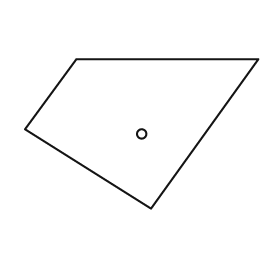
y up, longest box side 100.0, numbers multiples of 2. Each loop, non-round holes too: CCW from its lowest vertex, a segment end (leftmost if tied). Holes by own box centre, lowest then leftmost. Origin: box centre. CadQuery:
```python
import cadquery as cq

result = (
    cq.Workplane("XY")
    .moveTo(4.0, -32.0)
    .lineTo(50.0, 32.0)
    .lineTo(-28.0, 32.0)
    .lineTo(-50.0, 2.0)
    .close()
    .moveTo(0.0, 0.0)
    .circle(2.0)
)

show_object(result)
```